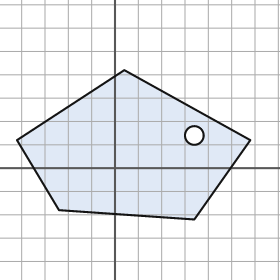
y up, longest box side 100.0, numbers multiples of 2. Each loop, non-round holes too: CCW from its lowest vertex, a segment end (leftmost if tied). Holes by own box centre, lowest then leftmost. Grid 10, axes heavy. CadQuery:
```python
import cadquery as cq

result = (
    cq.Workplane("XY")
    .moveTo(34.0, -22.0)
    .lineTo(58.0, 12.0)
    .lineTo(4.0, 42.0)
    .lineTo(-42.0, 12.0)
    .lineTo(-24.0, -18.0)
    .close()
    .moveTo(34.0, 14.0)
    .circle(4.0)
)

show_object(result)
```